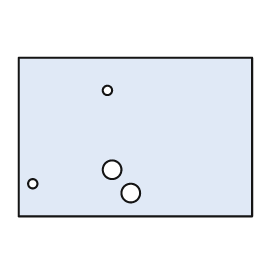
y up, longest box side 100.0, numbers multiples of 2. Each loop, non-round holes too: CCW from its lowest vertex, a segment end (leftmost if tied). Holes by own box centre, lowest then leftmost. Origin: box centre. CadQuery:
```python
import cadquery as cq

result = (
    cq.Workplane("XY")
    .moveTo(-50.0, -34.0)
    .lineTo(50.0, -34.0)
    .lineTo(50.0, 34.0)
    .lineTo(-50.0, 34.0)
    .close()
    .moveTo(-2.0, -24.0)
    .circle(4.0)
    .moveTo(-44.0, -20.0)
    .circle(2.0)
    .moveTo(-10.0, -14.0)
    .circle(4.0)
    .moveTo(-12.0, 20.0)
    .circle(2.0)
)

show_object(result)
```